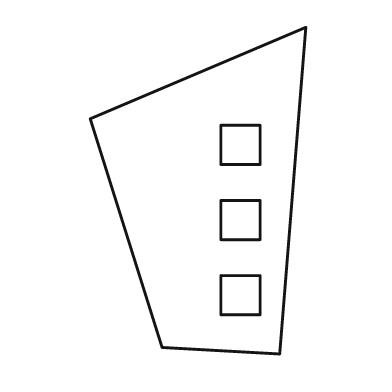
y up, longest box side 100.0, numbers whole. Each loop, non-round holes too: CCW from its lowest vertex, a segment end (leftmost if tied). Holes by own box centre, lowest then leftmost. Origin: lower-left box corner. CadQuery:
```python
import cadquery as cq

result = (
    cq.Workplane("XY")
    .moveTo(58.0, 0.0)
    .lineTo(66.0, 100.0)
    .lineTo(0.0, 72.0)
    .lineTo(22.0, 2.0)
    .close()
    .moveTo(40.0, 12.0)
    .lineTo(52.0, 12.0)
    .lineTo(52.0, 24.0)
    .lineTo(40.0, 24.0)
    .close()
    .moveTo(40.0, 35.0)
    .lineTo(52.0, 35.0)
    .lineTo(52.0, 47.0)
    .lineTo(40.0, 47.0)
    .close()
    .moveTo(40.0, 58.0)
    .lineTo(52.0, 58.0)
    .lineTo(52.0, 70.0)
    .lineTo(40.0, 70.0)
    .close()
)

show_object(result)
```